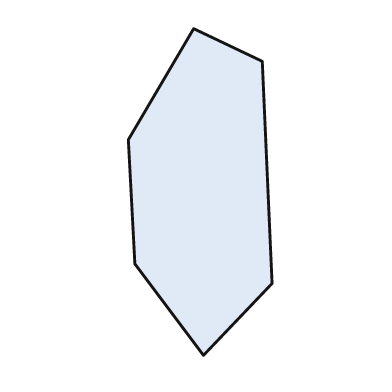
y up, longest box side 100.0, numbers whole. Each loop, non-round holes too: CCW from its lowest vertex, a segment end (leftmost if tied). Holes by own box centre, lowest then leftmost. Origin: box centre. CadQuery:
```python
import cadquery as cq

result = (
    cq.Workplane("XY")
    .moveTo(1.0, -50.0)
    .lineTo(22.0, -28.0)
    .lineTo(19.0, 40.0)
    .lineTo(-2.0, 50.0)
    .lineTo(-22.0, 16.0)
    .lineTo(-20.0, -22.0)
    .close()
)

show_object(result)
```